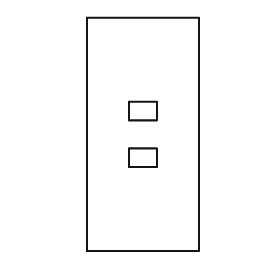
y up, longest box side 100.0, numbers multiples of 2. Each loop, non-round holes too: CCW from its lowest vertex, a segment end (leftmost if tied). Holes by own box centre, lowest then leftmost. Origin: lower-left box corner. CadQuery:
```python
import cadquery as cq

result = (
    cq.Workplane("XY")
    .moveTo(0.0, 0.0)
    .lineTo(48.0, 0.0)
    .lineTo(48.0, 100.0)
    .lineTo(0.0, 100.0)
    .close()
    .moveTo(18.0, 36.0)
    .lineTo(30.0, 36.0)
    .lineTo(30.0, 44.0)
    .lineTo(18.0, 44.0)
    .close()
    .moveTo(18.0, 56.0)
    .lineTo(30.0, 56.0)
    .lineTo(30.0, 64.0)
    .lineTo(18.0, 64.0)
    .close()
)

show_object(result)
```